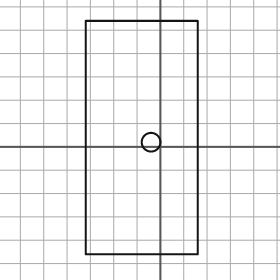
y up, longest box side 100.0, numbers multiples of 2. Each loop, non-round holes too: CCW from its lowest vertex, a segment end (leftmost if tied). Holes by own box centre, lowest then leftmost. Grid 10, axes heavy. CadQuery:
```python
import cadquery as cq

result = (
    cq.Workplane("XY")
    .moveTo(-32.0, -46.0)
    .lineTo(16.0, -46.0)
    .lineTo(16.0, 54.0)
    .lineTo(-32.0, 54.0)
    .close()
    .moveTo(-4.0, 2.0)
    .circle(4.0)
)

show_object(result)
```